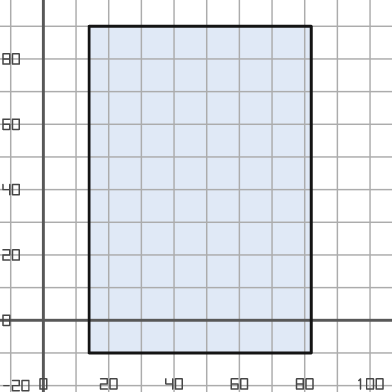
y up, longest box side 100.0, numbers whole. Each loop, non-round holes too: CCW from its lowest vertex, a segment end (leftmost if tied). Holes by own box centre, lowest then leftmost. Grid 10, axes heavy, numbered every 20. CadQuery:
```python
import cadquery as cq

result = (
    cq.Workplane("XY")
    .moveTo(14.0, -10.0)
    .lineTo(82.0, -10.0)
    .lineTo(82.0, 90.0)
    .lineTo(14.0, 90.0)
    .close()
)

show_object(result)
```